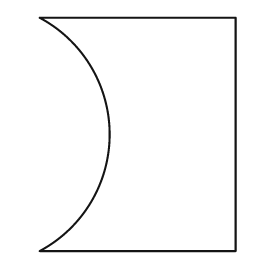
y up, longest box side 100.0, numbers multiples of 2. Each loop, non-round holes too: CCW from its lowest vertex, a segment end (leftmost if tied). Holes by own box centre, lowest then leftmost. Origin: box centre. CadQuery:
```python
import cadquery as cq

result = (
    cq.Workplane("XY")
    .moveTo(-42.0, -50.0)
    .lineTo(42.0, -50.0)
    .lineTo(42.0, 50.0)
    .lineTo(-42.0, 50.0)
    .threePointArc((-12.0, 0.0), (-42.0, -50.0))
    .close()
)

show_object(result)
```